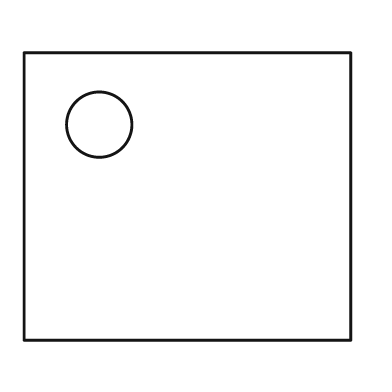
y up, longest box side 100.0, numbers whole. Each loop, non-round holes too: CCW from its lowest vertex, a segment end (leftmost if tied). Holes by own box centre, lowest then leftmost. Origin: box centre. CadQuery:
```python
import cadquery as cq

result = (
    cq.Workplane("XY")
    .moveTo(-50.0, -44.0)
    .lineTo(50.0, -44.0)
    .lineTo(50.0, 44.0)
    .lineTo(-50.0, 44.0)
    .close()
    .moveTo(-27.0, 22.0)
    .circle(10.0)
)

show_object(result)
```